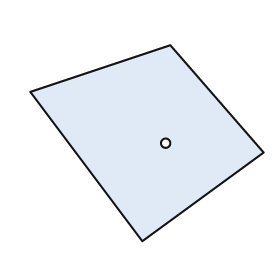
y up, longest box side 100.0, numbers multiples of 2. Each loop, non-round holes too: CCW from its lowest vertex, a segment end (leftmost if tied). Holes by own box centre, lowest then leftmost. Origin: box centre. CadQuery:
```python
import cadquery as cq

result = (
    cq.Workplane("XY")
    .moveTo(-2.0, -42.0)
    .lineTo(50.0, -4.0)
    .lineTo(10.0, 42.0)
    .lineTo(-50.0, 22.0)
    .close()
    .moveTo(8.0, 0.0)
    .circle(2.0)
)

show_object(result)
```